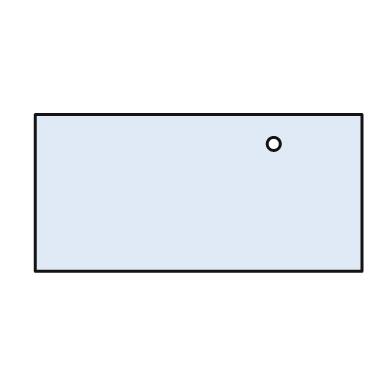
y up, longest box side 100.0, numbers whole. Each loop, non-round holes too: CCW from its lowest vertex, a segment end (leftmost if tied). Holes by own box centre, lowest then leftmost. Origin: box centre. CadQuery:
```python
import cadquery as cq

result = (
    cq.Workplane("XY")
    .moveTo(-50.0, -24.0)
    .lineTo(50.0, -24.0)
    .lineTo(50.0, 24.0)
    .lineTo(-50.0, 24.0)
    .close()
    .moveTo(23.0, 15.0)
    .circle(2.0)
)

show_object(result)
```